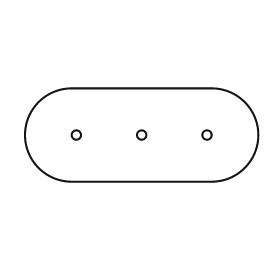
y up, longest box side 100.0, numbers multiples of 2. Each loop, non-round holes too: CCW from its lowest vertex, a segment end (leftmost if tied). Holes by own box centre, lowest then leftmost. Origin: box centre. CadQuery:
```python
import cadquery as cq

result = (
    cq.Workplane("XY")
    .moveTo(-30.0, -20.0)
    .lineTo(30.0, -20.0)
    .threePointArc((50.0, 0.0), (30.0, 20.0))
    .lineTo(-30.0, 20.0)
    .threePointArc((-50.0, 0.0), (-30.0, -20.0))
    .close()
    .moveTo(-28.0, 0.0)
    .circle(2.0)
    .moveTo(0.0, 0.0)
    .circle(2.0)
    .moveTo(28.0, 0.0)
    .circle(2.0)
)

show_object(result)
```